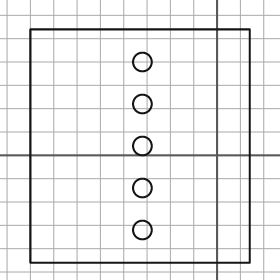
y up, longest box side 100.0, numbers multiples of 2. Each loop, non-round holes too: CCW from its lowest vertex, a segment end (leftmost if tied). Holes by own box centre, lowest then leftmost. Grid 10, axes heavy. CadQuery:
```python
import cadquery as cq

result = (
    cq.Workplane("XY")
    .moveTo(-80.0, -46.0)
    .lineTo(14.0, -46.0)
    .lineTo(14.0, 54.0)
    .lineTo(-80.0, 54.0)
    .close()
    .moveTo(-32.0, -32.0)
    .circle(4.0)
    .moveTo(-32.0, -14.0)
    .circle(4.0)
    .moveTo(-32.0, 4.0)
    .circle(4.0)
    .moveTo(-32.0, 22.0)
    .circle(4.0)
    .moveTo(-32.0, 40.0)
    .circle(4.0)
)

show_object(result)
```